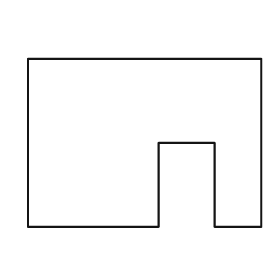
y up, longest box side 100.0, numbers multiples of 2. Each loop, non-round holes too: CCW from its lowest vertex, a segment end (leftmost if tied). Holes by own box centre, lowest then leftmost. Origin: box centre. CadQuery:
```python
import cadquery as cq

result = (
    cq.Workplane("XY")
    .moveTo(-50.0, -36.0)
    .lineTo(6.0, -36.0)
    .lineTo(6.0, 0.0)
    .lineTo(30.0, 0.0)
    .lineTo(30.0, -36.0)
    .lineTo(50.0, -36.0)
    .lineTo(50.0, 36.0)
    .lineTo(-50.0, 36.0)
    .close()
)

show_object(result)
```